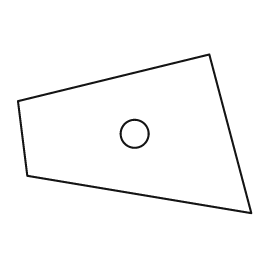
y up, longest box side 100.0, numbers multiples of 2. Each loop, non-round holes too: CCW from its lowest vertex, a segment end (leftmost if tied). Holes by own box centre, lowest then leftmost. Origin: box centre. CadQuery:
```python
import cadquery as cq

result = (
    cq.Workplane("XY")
    .moveTo(50.0, -34.0)
    .lineTo(32.0, 34.0)
    .lineTo(-50.0, 14.0)
    .lineTo(-46.0, -18.0)
    .close()
    .moveTo(0.0, 0.0)
    .circle(6.0)
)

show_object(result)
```